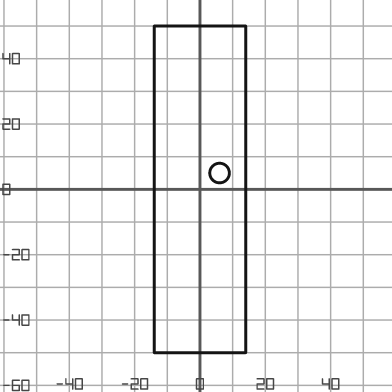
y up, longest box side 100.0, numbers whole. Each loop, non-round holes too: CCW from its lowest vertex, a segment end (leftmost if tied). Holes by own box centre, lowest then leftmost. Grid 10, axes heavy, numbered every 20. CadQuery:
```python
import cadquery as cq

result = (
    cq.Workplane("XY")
    .moveTo(-14.0, -50.0)
    .lineTo(14.0, -50.0)
    .lineTo(14.0, 50.0)
    .lineTo(-14.0, 50.0)
    .close()
    .moveTo(6.0, 5.0)
    .circle(3.0)
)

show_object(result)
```